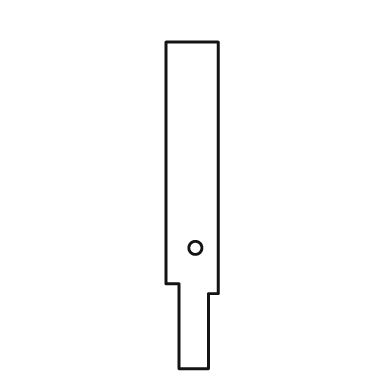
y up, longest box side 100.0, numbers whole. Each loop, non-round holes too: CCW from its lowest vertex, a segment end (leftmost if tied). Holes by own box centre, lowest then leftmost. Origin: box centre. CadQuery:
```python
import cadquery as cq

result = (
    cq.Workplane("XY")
    .moveTo(-4.0, -50.0)
    .lineTo(5.0, -50.0)
    .lineTo(5.0, -27.0)
    .lineTo(8.0, -27.0)
    .lineTo(8.0, 50.0)
    .lineTo(-8.0, 50.0)
    .lineTo(-8.0, -24.0)
    .lineTo(-4.0, -24.0)
    .close()
    .moveTo(1.0, -13.0)
    .circle(2.0)
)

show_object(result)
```